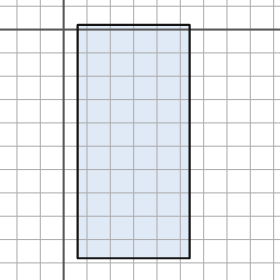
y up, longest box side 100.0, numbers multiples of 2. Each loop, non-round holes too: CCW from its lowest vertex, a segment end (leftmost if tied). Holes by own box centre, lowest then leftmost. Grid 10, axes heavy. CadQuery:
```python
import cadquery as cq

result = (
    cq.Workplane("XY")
    .moveTo(6.0, -98.0)
    .lineTo(54.0, -98.0)
    .lineTo(54.0, 2.0)
    .lineTo(6.0, 2.0)
    .close()
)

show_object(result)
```